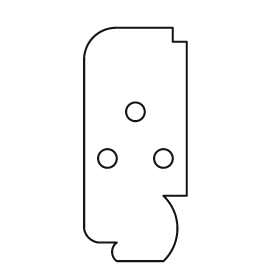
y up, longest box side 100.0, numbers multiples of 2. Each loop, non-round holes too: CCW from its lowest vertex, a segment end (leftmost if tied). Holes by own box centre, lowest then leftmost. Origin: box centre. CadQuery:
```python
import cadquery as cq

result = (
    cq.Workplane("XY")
    .moveTo(-8.0, -50.0)
    .lineTo(12.0, -50.0)
    .threePointArc((18.0, -36.0), (12.0, -22.0))
    .lineTo(22.0, -22.0)
    .lineTo(22.0, 44.0)
    .lineTo(16.0, 44.0)
    .lineTo(16.0, 50.0)
    .lineTo(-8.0, 50.0)
    .threePointArc((-18.0, 46.0), (-22.0, 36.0))
    .lineTo(-22.0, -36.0)
    .threePointArc((-20.0, -40.0), (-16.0, -42.0))
    .lineTo(-8.0, -42.0)
    .threePointArc((-10.0, -46.0), (-8.0, -50.0))
    .close()
    .moveTo(-12.0, -6.0)
    .circle(4.0)
    .moveTo(12.0, -6.0)
    .circle(4.0)
    .moveTo(0.0, 14.0)
    .circle(4.0)
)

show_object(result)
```